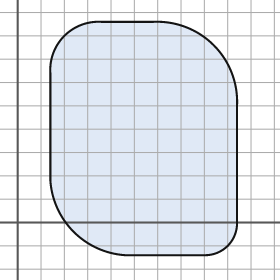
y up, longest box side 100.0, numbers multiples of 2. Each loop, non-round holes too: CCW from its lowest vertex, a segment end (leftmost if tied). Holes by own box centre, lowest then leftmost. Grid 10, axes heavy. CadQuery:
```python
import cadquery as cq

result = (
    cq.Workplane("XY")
    .moveTo(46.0, -14.0)
    .lineTo(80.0, -14.0)
    .threePointArc((90.0, -10.0), (94.0, 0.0))
    .lineTo(94.0, 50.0)
    .threePointArc((84.0, 76.0), (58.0, 86.0))
    .lineTo(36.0, 86.0)
    .threePointArc((20.0, 80.0), (14.0, 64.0))
    .lineTo(14.0, 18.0)
    .threePointArc((24.0, -4.0), (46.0, -14.0))
    .close()
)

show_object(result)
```